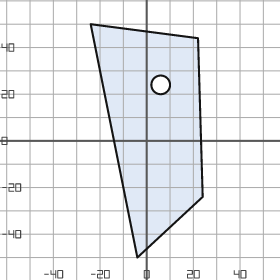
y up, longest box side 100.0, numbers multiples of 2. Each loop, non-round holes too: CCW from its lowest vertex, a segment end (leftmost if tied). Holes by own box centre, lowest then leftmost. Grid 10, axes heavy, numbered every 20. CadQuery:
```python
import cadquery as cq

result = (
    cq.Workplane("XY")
    .moveTo(-4.0, -50.0)
    .lineTo(24.0, -24.0)
    .lineTo(22.0, 44.0)
    .lineTo(-24.0, 50.0)
    .close()
    .moveTo(6.0, 24.0)
    .circle(4.0)
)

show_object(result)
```